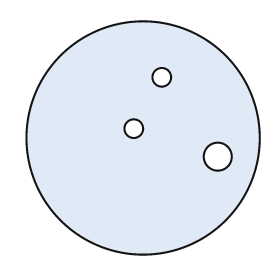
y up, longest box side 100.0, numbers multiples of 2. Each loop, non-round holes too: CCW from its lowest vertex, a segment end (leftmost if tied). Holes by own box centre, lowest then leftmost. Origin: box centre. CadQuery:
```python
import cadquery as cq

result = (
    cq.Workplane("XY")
    .moveTo(0.0, 0.0)
    .circle(50.0)
    .moveTo(32.0, -8.0)
    .circle(6.0)
    .moveTo(-4.0, 4.0)
    .circle(4.0)
    .moveTo(8.0, 26.0)
    .circle(4.0)
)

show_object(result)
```